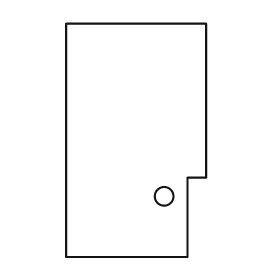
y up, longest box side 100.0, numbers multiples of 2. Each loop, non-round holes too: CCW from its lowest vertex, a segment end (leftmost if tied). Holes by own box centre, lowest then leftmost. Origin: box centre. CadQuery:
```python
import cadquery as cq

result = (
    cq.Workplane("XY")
    .moveTo(-30.0, -50.0)
    .lineTo(22.0, -50.0)
    .lineTo(22.0, -16.0)
    .lineTo(30.0, -16.0)
    .lineTo(30.0, 50.0)
    .lineTo(-30.0, 50.0)
    .close()
    .moveTo(12.0, -24.0)
    .circle(4.0)
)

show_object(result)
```